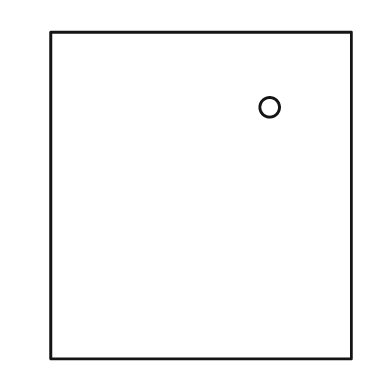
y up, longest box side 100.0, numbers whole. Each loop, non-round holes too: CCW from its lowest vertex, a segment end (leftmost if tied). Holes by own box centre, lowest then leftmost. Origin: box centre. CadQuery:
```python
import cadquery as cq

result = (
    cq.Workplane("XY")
    .moveTo(-46.0, -50.0)
    .lineTo(46.0, -50.0)
    .lineTo(46.0, 50.0)
    .lineTo(-46.0, 50.0)
    .close()
    .moveTo(21.0, 27.0)
    .circle(3.0)
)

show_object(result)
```